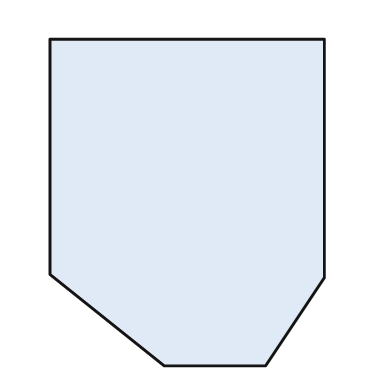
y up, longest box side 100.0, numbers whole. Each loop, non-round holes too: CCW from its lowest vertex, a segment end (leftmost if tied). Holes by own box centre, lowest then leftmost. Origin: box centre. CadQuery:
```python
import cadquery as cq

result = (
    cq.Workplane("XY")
    .moveTo(-7.0, -50.0)
    .lineTo(24.0, -50.0)
    .lineTo(42.0, -23.0)
    .lineTo(42.0, 50.0)
    .lineTo(-42.0, 50.0)
    .lineTo(-42.0, -22.0)
    .close()
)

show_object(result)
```